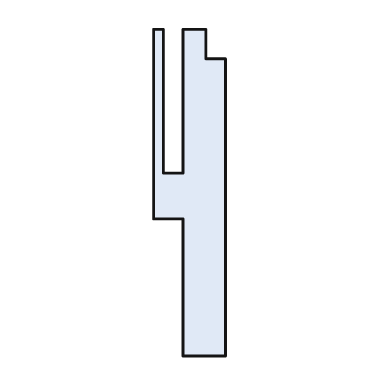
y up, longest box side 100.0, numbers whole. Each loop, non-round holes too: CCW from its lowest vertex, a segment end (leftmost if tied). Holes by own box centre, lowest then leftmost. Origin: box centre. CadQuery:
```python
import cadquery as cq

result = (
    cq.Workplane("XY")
    .moveTo(-2.0, -50.0)
    .lineTo(11.0, -50.0)
    .lineTo(11.0, 41.0)
    .lineTo(5.0, 41.0)
    .lineTo(5.0, 50.0)
    .lineTo(-2.0, 50.0)
    .lineTo(-2.0, 6.0)
    .lineTo(-8.0, 6.0)
    .lineTo(-8.0, 50.0)
    .lineTo(-11.0, 50.0)
    .lineTo(-11.0, -8.0)
    .lineTo(-2.0, -8.0)
    .close()
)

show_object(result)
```